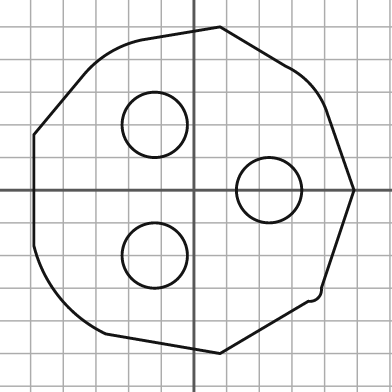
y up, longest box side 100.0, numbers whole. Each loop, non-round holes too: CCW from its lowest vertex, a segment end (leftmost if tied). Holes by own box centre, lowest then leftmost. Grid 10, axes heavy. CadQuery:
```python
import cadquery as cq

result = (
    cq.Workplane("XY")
    .moveTo(8.0, -50.0)
    .lineTo(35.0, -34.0)
    .threePointArc((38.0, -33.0), (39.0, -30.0))
    .lineTo(49.0, 0.0)
    .lineTo(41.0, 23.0)
    .threePointArc((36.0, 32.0), (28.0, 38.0))
    .lineTo(8.0, 50.0)
    .lineTo(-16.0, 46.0)
    .threePointArc((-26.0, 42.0), (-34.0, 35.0))
    .lineTo(-49.0, 17.0)
    .lineTo(-49.0, -17.0)
    .threePointArc((-41.0, -33.0), (-27.0, -44.0))
    .close()
    .moveTo(-12.0, -20.0)
    .circle(10.0)
    .moveTo(23.0, 0.0)
    .circle(10.0)
    .moveTo(-12.0, 20.0)
    .circle(10.0)
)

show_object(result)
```